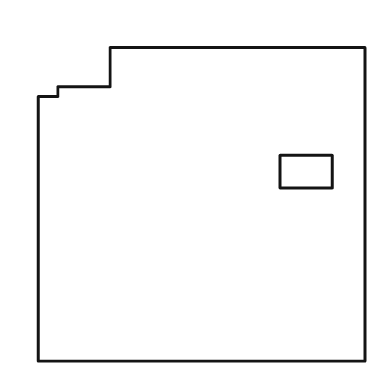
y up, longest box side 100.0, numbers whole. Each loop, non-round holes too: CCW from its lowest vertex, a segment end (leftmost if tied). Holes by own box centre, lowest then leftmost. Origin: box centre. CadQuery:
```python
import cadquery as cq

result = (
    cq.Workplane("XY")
    .moveTo(-50.0, -48.0)
    .lineTo(50.0, -48.0)
    .lineTo(50.0, 48.0)
    .lineTo(-28.0, 48.0)
    .lineTo(-28.0, 36.0)
    .lineTo(-44.0, 36.0)
    .lineTo(-44.0, 33.0)
    .lineTo(-50.0, 33.0)
    .close()
    .moveTo(24.0, 5.0)
    .lineTo(40.0, 5.0)
    .lineTo(40.0, 15.0)
    .lineTo(24.0, 15.0)
    .close()
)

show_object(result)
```